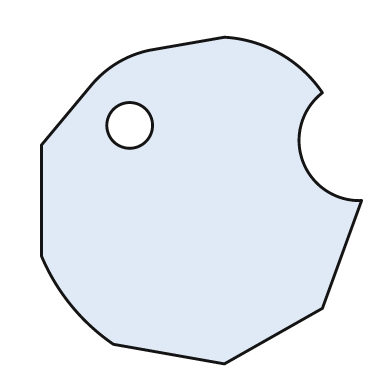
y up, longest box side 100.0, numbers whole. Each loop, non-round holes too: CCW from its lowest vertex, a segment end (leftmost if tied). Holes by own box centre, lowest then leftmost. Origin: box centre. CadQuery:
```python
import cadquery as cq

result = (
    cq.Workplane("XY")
    .moveTo(7.0, -50.0)
    .lineTo(37.0, -33.0)
    .lineTo(49.0, 0.0)
    .threePointArc((31.0, 12.0), (37.0, 33.0))
    .threePointArc((24.0, 45.0), (7.0, 50.0))
    .lineTo(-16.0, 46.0)
    .threePointArc((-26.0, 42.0), (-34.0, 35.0))
    .lineTo(-49.0, 17.0)
    .lineTo(-49.0, -17.0)
    .threePointArc((-40.0, -32.0), (-27.0, -44.0))
    .close()
    .moveTo(-22.0, 23.0)
    .circle(7.0)
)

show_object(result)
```